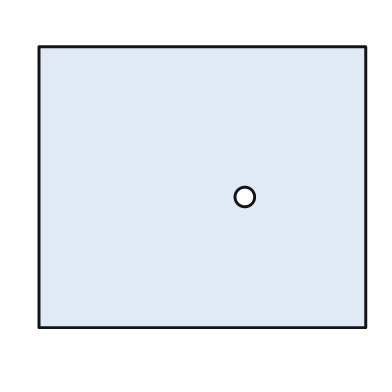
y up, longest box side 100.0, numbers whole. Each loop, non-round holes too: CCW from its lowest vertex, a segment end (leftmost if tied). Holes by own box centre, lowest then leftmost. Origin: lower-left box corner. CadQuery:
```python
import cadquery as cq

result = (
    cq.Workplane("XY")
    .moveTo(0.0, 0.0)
    .lineTo(100.0, 0.0)
    .lineTo(100.0, 86.0)
    .lineTo(0.0, 86.0)
    .close()
    .moveTo(63.0, 40.0)
    .circle(3.0)
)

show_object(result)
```